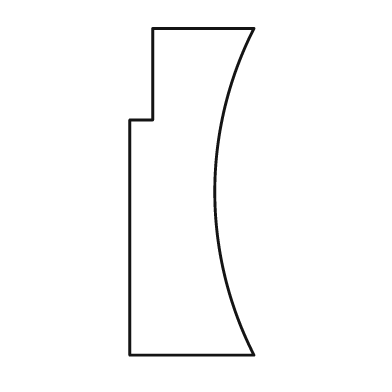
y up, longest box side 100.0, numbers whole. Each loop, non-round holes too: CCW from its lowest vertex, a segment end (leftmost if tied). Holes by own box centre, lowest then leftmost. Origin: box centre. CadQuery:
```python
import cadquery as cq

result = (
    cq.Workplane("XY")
    .moveTo(-19.0, -50.0)
    .lineTo(19.0, -50.0)
    .threePointArc((7.0, 0.0), (19.0, 50.0))
    .lineTo(-12.0, 50.0)
    .lineTo(-12.0, 22.0)
    .lineTo(-19.0, 22.0)
    .close()
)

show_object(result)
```